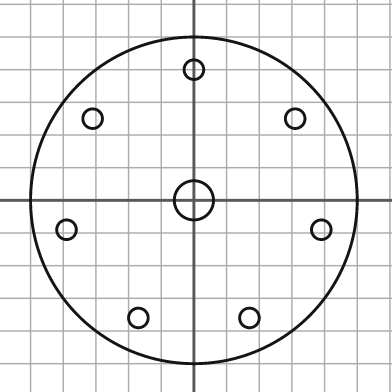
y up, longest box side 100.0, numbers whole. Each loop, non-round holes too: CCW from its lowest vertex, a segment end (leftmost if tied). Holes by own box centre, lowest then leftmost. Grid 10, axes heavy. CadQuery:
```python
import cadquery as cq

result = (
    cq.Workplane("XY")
    .moveTo(0.0, 0.0)
    .circle(50.0)
    .moveTo(-17.0, -36.0)
    .circle(3.0)
    .moveTo(17.0, -36.0)
    .circle(3.0)
    .moveTo(-39.0, -9.0)
    .circle(3.0)
    .moveTo(39.0, -9.0)
    .circle(3.0)
    .moveTo(0.0, 0.0)
    .circle(6.0)
    .moveTo(-31.0, 25.0)
    .circle(3.0)
    .moveTo(31.0, 25.0)
    .circle(3.0)
    .moveTo(0.0, 40.0)
    .circle(3.0)
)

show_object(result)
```